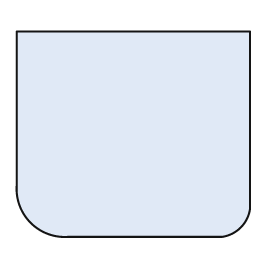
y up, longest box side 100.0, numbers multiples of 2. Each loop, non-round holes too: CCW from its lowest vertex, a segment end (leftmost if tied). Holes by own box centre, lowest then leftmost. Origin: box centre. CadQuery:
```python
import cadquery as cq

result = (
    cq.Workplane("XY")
    .moveTo(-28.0, -44.0)
    .lineTo(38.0, -44.0)
    .threePointArc((46.0, -40.0), (50.0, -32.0))
    .lineTo(50.0, 44.0)
    .lineTo(-50.0, 44.0)
    .lineTo(-50.0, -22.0)
    .threePointArc((-44.0, -38.0), (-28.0, -44.0))
    .close()
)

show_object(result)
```